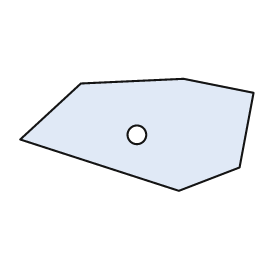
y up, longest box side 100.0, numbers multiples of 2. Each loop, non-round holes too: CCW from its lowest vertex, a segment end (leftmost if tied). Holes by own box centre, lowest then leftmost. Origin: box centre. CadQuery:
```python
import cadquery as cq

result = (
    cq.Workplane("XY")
    .moveTo(18.0, -24.0)
    .lineTo(44.0, -14.0)
    .lineTo(50.0, 18.0)
    .lineTo(20.0, 24.0)
    .lineTo(-24.0, 22.0)
    .lineTo(-50.0, -2.0)
    .close()
    .moveTo(0.0, 0.0)
    .circle(4.0)
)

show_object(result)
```